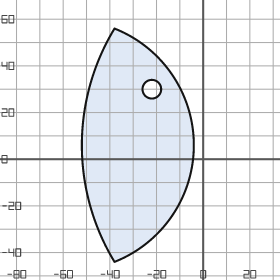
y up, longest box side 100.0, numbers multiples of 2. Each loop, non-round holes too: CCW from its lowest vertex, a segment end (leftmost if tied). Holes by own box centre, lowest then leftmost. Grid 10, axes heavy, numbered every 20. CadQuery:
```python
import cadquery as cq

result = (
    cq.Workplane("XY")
    .moveTo(-38.0, -44.0)
    .threePointArc((-4.0, 6.0), (-38.0, 56.0))
    .threePointArc((-52.0, 6.0), (-38.0, -44.0))
    .close()
    .moveTo(-22.0, 30.0)
    .circle(4.0)
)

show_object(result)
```